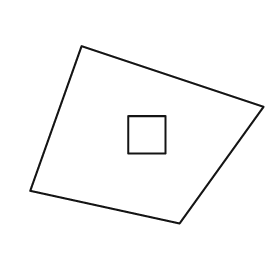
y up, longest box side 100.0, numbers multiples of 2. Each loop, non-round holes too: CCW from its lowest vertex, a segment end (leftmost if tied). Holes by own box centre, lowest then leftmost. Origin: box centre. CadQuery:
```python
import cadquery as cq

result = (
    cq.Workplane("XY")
    .moveTo(14.0, -38.0)
    .lineTo(50.0, 12.0)
    .lineTo(-28.0, 38.0)
    .lineTo(-50.0, -24.0)
    .close()
    .moveTo(-8.0, -8.0)
    .lineTo(8.0, -8.0)
    .lineTo(8.0, 8.0)
    .lineTo(-8.0, 8.0)
    .close()
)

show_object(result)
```